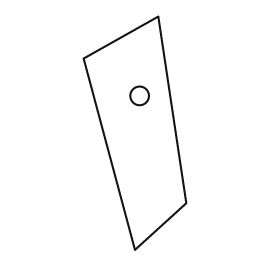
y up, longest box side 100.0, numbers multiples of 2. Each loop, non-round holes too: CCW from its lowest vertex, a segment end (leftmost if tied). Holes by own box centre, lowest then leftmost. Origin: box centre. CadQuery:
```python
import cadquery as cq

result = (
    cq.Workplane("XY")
    .moveTo(0.0, -50.0)
    .lineTo(22.0, -30.0)
    .lineTo(10.0, 50.0)
    .lineTo(-22.0, 32.0)
    .close()
    .moveTo(2.0, 16.0)
    .circle(4.0)
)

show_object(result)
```